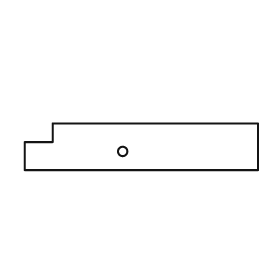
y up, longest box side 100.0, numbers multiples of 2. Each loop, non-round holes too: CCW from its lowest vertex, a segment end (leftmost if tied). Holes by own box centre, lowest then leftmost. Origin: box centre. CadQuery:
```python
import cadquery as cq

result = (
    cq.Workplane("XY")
    .moveTo(-50.0, -10.0)
    .lineTo(50.0, -10.0)
    .lineTo(50.0, 10.0)
    .lineTo(-38.0, 10.0)
    .lineTo(-38.0, 2.0)
    .lineTo(-50.0, 2.0)
    .close()
    .moveTo(-8.0, -2.0)
    .circle(2.0)
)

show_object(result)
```